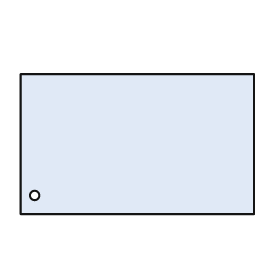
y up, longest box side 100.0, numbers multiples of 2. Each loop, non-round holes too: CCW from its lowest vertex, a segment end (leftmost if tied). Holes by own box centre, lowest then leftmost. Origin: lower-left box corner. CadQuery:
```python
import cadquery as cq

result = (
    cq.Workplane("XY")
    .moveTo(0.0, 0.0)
    .lineTo(100.0, 0.0)
    .lineTo(100.0, 60.0)
    .lineTo(0.0, 60.0)
    .close()
    .moveTo(6.0, 8.0)
    .circle(2.0)
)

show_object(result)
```